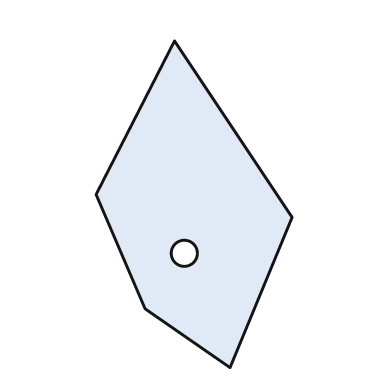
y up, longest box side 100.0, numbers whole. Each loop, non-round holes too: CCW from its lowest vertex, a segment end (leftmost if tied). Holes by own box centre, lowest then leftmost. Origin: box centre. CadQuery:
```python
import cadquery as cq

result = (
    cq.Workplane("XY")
    .moveTo(11.0, -50.0)
    .lineTo(30.0, -4.0)
    .lineTo(-6.0, 50.0)
    .lineTo(-30.0, 3.0)
    .lineTo(-15.0, -32.0)
    .close()
    .moveTo(-3.0, -15.0)
    .circle(4.0)
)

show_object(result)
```